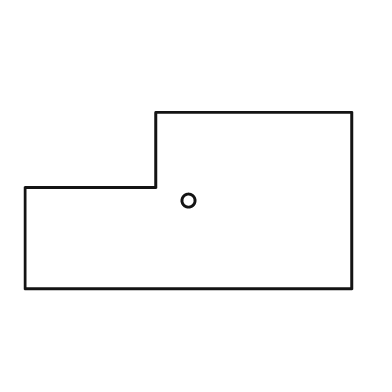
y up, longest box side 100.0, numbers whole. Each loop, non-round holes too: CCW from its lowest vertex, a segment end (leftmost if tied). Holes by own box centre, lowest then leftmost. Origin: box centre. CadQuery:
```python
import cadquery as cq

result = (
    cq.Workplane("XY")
    .moveTo(-50.0, -27.0)
    .lineTo(50.0, -27.0)
    .lineTo(50.0, 27.0)
    .lineTo(-10.0, 27.0)
    .lineTo(-10.0, 4.0)
    .lineTo(-50.0, 4.0)
    .close()
    .moveTo(0.0, 0.0)
    .circle(2.0)
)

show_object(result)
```